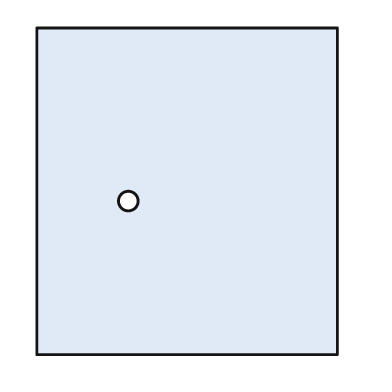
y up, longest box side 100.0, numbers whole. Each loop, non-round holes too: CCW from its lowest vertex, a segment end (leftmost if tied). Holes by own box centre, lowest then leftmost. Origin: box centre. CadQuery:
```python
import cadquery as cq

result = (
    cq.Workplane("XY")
    .moveTo(-46.0, -50.0)
    .lineTo(46.0, -50.0)
    .lineTo(46.0, 50.0)
    .lineTo(-46.0, 50.0)
    .close()
    .moveTo(-18.0, -3.0)
    .circle(3.0)
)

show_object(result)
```